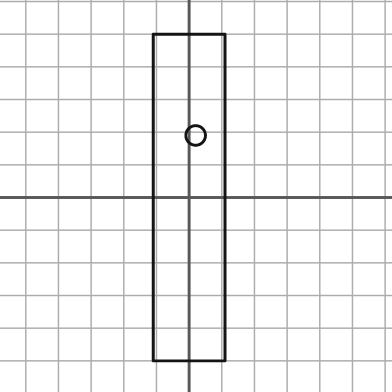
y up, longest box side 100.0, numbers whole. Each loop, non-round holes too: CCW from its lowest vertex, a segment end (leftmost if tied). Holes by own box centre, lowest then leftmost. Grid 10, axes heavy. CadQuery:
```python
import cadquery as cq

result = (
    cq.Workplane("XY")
    .moveTo(-11.0, -50.0)
    .lineTo(11.0, -50.0)
    .lineTo(11.0, 50.0)
    .lineTo(-11.0, 50.0)
    .close()
    .moveTo(2.0, 19.0)
    .circle(3.0)
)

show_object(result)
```